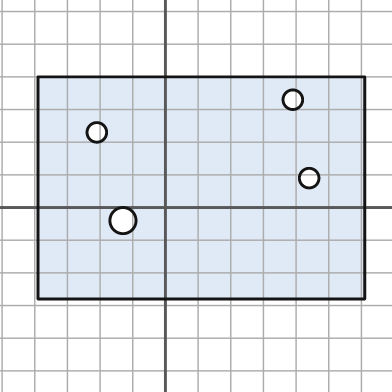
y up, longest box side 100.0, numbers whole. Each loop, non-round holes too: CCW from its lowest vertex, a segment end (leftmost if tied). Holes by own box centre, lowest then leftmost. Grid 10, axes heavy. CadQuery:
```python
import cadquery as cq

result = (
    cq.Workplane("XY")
    .moveTo(-39.0, -28.0)
    .lineTo(61.0, -28.0)
    .lineTo(61.0, 40.0)
    .lineTo(-39.0, 40.0)
    .close()
    .moveTo(-13.0, -4.0)
    .circle(4.0)
    .moveTo(44.0, 9.0)
    .circle(3.0)
    .moveTo(-21.0, 23.0)
    .circle(3.0)
    .moveTo(39.0, 33.0)
    .circle(3.0)
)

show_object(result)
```